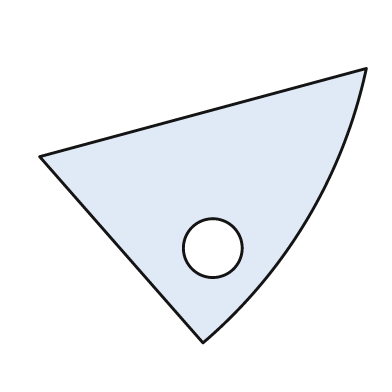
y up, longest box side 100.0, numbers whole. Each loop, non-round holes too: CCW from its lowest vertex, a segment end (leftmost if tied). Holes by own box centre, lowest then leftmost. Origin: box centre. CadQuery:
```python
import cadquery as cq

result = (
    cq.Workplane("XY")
    .moveTo(0.0, -42.0)
    .threePointArc((32.0, -4.0), (50.0, 42.0))
    .lineTo(-50.0, 15.0)
    .close()
    .moveTo(3.0, -13.0)
    .circle(9.0)
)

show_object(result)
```